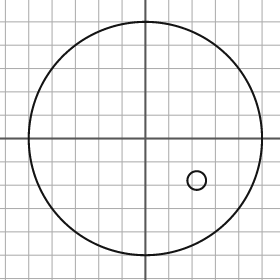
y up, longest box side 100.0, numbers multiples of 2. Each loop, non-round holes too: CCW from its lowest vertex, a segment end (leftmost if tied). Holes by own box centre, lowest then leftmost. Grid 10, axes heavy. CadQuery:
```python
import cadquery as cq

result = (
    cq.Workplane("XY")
    .moveTo(0.0, 0.0)
    .circle(50.0)
    .moveTo(22.0, -18.0)
    .circle(4.0)
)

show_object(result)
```